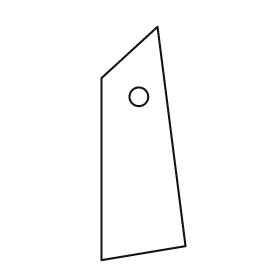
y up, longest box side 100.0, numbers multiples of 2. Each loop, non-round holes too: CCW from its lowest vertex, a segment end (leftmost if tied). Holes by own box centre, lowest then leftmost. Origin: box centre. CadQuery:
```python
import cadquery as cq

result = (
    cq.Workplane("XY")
    .moveTo(-18.0, -50.0)
    .lineTo(18.0, -44.0)
    .lineTo(6.0, 50.0)
    .lineTo(-18.0, 28.0)
    .close()
    .moveTo(-2.0, 20.0)
    .circle(4.0)
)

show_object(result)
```